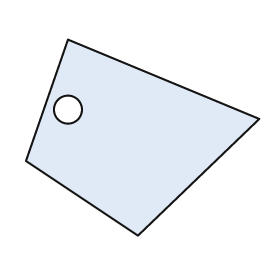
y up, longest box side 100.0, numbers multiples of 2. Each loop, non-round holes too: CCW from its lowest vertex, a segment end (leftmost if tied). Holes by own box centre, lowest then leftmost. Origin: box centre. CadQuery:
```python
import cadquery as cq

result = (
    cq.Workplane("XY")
    .moveTo(-2.0, -42.0)
    .lineTo(50.0, 8.0)
    .lineTo(-32.0, 42.0)
    .lineTo(-50.0, -10.0)
    .close()
    .moveTo(-32.0, 12.0)
    .circle(6.0)
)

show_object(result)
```